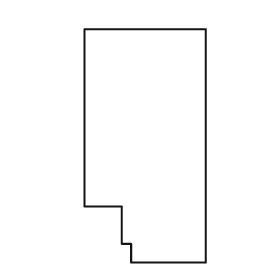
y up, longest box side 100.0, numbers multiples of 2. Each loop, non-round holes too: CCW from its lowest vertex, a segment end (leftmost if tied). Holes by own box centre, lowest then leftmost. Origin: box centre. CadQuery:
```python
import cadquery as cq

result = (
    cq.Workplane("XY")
    .moveTo(-6.0, -50.0)
    .lineTo(26.0, -50.0)
    .lineTo(26.0, 50.0)
    .lineTo(-26.0, 50.0)
    .lineTo(-26.0, -26.0)
    .lineTo(-10.0, -26.0)
    .lineTo(-10.0, -42.0)
    .lineTo(-6.0, -42.0)
    .close()
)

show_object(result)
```